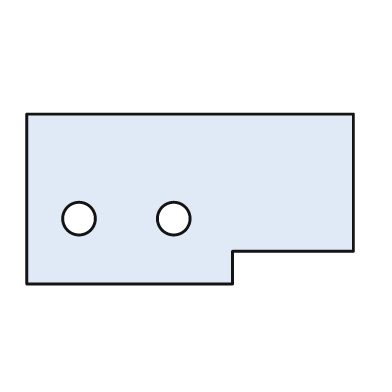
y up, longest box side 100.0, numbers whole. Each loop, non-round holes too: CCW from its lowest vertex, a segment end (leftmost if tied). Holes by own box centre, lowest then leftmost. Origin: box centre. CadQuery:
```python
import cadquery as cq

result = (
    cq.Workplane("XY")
    .moveTo(-50.0, -26.0)
    .lineTo(13.0, -26.0)
    .lineTo(13.0, -16.0)
    .lineTo(50.0, -16.0)
    .lineTo(50.0, 26.0)
    .lineTo(-50.0, 26.0)
    .close()
    .moveTo(-34.0, -6.0)
    .circle(5.0)
    .moveTo(-5.0, -6.0)
    .circle(5.0)
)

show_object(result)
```